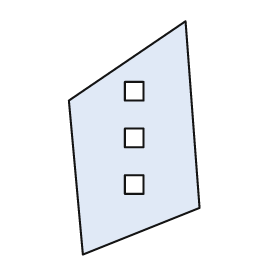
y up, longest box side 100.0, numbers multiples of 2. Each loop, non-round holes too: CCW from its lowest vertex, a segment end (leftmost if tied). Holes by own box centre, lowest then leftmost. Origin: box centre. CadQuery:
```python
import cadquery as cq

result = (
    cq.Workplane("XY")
    .moveTo(-22.0, -50.0)
    .lineTo(28.0, -30.0)
    .lineTo(22.0, 50.0)
    .lineTo(-28.0, 16.0)
    .close()
    .moveTo(-4.0, -24.0)
    .lineTo(4.0, -24.0)
    .lineTo(4.0, -16.0)
    .lineTo(-4.0, -16.0)
    .close()
    .moveTo(-4.0, -4.0)
    .lineTo(4.0, -4.0)
    .lineTo(4.0, 4.0)
    .lineTo(-4.0, 4.0)
    .close()
    .moveTo(-4.0, 16.0)
    .lineTo(4.0, 16.0)
    .lineTo(4.0, 24.0)
    .lineTo(-4.0, 24.0)
    .close()
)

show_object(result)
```